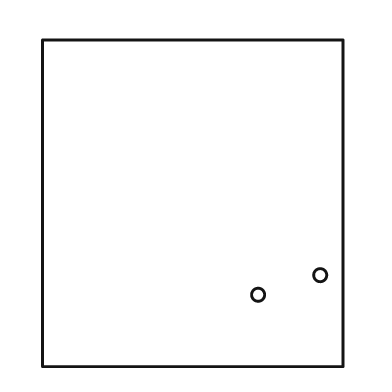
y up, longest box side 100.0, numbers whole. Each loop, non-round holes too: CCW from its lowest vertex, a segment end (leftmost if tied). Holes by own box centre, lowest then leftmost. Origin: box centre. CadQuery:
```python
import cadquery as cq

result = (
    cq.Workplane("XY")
    .moveTo(-46.0, -50.0)
    .lineTo(46.0, -50.0)
    .lineTo(46.0, 50.0)
    .lineTo(-46.0, 50.0)
    .close()
    .moveTo(20.0, -28.0)
    .circle(2.0)
    .moveTo(39.0, -22.0)
    .circle(2.0)
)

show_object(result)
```